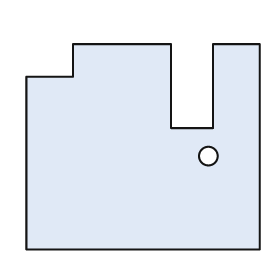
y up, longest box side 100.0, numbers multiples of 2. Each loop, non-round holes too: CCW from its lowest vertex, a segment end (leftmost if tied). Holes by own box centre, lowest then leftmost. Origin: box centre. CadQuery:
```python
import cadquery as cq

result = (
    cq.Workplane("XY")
    .moveTo(-50.0, -44.0)
    .lineTo(50.0, -44.0)
    .lineTo(50.0, 44.0)
    .lineTo(30.0, 44.0)
    .lineTo(30.0, 8.0)
    .lineTo(12.0, 8.0)
    .lineTo(12.0, 44.0)
    .lineTo(-30.0, 44.0)
    .lineTo(-30.0, 30.0)
    .lineTo(-50.0, 30.0)
    .close()
    .moveTo(28.0, -4.0)
    .circle(4.0)
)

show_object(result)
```